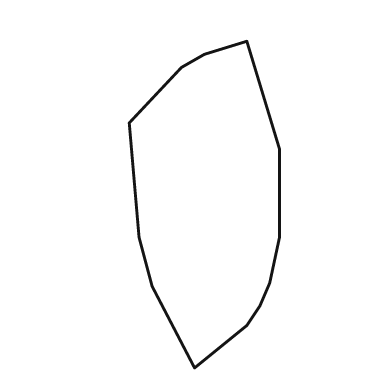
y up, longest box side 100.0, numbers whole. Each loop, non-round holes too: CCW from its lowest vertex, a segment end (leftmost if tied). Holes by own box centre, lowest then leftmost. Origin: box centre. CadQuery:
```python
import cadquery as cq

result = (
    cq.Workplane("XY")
    .moveTo(-3.0, -50.0)
    .lineTo(13.0, -37.0)
    .lineTo(17.0, -31.0)
    .lineTo(20.0, -24.0)
    .lineTo(23.0, -10.0)
    .lineTo(23.0, 17.0)
    .lineTo(13.0, 50.0)
    .lineTo(0.0, 46.0)
    .lineTo(-7.0, 42.0)
    .lineTo(-23.0, 25.0)
    .lineTo(-20.0, -10.0)
    .lineTo(-16.0, -25.0)
    .close()
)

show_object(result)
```